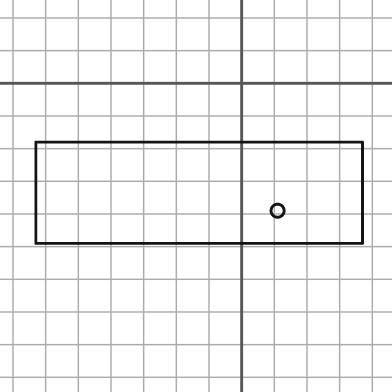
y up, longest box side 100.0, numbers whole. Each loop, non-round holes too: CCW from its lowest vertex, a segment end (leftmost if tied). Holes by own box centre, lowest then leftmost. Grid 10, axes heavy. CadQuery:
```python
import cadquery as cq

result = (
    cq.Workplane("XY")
    .moveTo(-63.0, -49.0)
    .lineTo(37.0, -49.0)
    .lineTo(37.0, -18.0)
    .lineTo(-63.0, -18.0)
    .close()
    .moveTo(11.0, -39.0)
    .circle(2.0)
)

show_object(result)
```